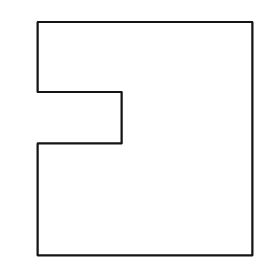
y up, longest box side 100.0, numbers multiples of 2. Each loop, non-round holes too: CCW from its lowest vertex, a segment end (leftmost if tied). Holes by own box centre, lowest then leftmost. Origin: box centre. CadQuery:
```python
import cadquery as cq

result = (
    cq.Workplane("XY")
    .moveTo(-46.0, -50.0)
    .lineTo(46.0, -50.0)
    .lineTo(46.0, 50.0)
    .lineTo(-46.0, 50.0)
    .lineTo(-46.0, 20.0)
    .lineTo(-10.0, 20.0)
    .lineTo(-10.0, -2.0)
    .lineTo(-46.0, -2.0)
    .close()
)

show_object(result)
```